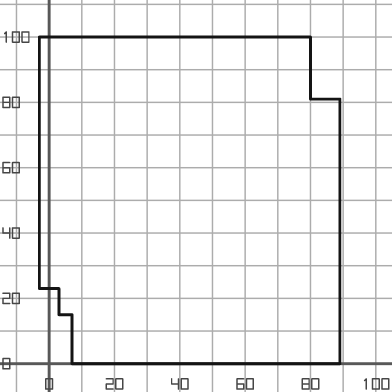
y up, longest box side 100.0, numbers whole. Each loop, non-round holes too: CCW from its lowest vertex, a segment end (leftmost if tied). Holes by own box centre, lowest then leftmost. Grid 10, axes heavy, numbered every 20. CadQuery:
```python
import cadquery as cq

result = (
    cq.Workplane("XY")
    .moveTo(7.0, 0.0)
    .lineTo(89.0, 0.0)
    .lineTo(89.0, 81.0)
    .lineTo(80.0, 81.0)
    .lineTo(80.0, 100.0)
    .lineTo(-3.0, 100.0)
    .lineTo(-3.0, 23.0)
    .lineTo(3.0, 23.0)
    .lineTo(3.0, 15.0)
    .lineTo(7.0, 15.0)
    .close()
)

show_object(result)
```